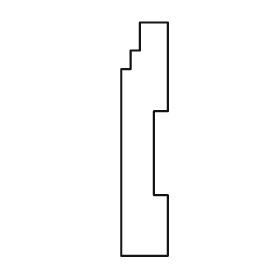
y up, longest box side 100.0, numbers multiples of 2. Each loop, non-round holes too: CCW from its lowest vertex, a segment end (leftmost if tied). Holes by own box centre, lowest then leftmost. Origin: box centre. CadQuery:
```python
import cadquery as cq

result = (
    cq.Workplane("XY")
    .moveTo(-10.0, -50.0)
    .lineTo(10.0, -50.0)
    .lineTo(10.0, -24.0)
    .lineTo(4.0, -24.0)
    .lineTo(4.0, 12.0)
    .lineTo(10.0, 12.0)
    .lineTo(10.0, 50.0)
    .lineTo(-2.0, 50.0)
    .lineTo(-2.0, 38.0)
    .lineTo(-6.0, 38.0)
    .lineTo(-6.0, 30.0)
    .lineTo(-10.0, 30.0)
    .close()
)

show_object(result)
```